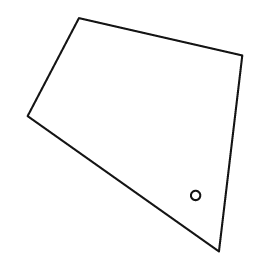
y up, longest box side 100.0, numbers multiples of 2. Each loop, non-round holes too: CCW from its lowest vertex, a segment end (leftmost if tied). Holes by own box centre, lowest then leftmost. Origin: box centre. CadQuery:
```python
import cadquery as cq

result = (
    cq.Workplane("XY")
    .moveTo(36.0, -50.0)
    .lineTo(46.0, 34.0)
    .lineTo(-24.0, 50.0)
    .lineTo(-46.0, 8.0)
    .close()
    .moveTo(26.0, -26.0)
    .circle(2.0)
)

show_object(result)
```